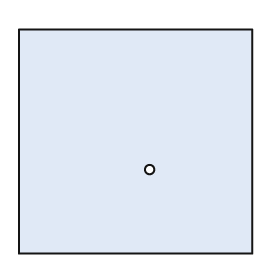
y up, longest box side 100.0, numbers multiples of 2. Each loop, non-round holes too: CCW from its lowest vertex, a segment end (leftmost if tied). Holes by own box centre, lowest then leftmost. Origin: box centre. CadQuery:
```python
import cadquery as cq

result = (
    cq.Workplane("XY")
    .moveTo(-50.0, -48.0)
    .lineTo(50.0, -48.0)
    .lineTo(50.0, 48.0)
    .lineTo(-50.0, 48.0)
    .close()
    .moveTo(6.0, -12.0)
    .circle(2.0)
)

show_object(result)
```